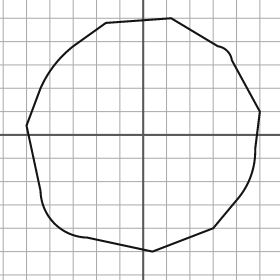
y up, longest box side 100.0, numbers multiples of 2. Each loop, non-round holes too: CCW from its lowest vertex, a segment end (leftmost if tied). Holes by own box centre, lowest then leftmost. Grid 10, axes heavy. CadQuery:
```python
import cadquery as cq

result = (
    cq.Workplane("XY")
    .moveTo(4.0, -50.0)
    .lineTo(30.0, -40.0)
    .lineTo(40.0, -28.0)
    .threePointArc((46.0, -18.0), (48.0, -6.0))
    .lineTo(50.0, 10.0)
    .lineTo(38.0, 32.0)
    .threePointArc((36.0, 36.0), (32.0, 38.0))
    .lineTo(12.0, 50.0)
    .lineTo(-16.0, 48.0)
    .lineTo(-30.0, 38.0)
    .threePointArc((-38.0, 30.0), (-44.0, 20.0))
    .lineTo(-50.0, 4.0)
    .lineTo(-44.0, -24.0)
    .threePointArc((-38.0, -38.0), (-24.0, -44.0))
    .close()
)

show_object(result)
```